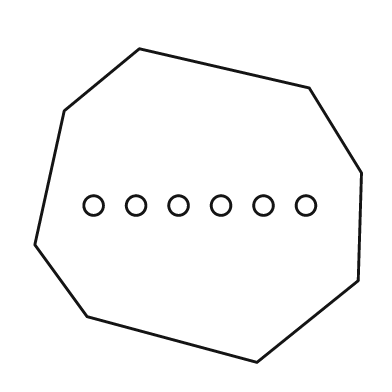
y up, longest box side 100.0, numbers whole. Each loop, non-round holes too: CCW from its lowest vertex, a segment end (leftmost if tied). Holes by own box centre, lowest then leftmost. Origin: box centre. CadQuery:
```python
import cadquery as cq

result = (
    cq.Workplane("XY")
    .moveTo(18.0, -48.0)
    .lineTo(49.0, -23.0)
    .lineTo(50.0, 10.0)
    .lineTo(34.0, 36.0)
    .lineTo(-18.0, 48.0)
    .lineTo(-41.0, 29.0)
    .lineTo(-50.0, -12.0)
    .lineTo(-34.0, -34.0)
    .close()
    .moveTo(-32.0, 0.0)
    .circle(3.0)
    .moveTo(-19.0, 0.0)
    .circle(3.0)
    .moveTo(-6.0, 0.0)
    .circle(3.0)
    .moveTo(7.0, 0.0)
    .circle(3.0)
    .moveTo(20.0, 0.0)
    .circle(3.0)
    .moveTo(33.0, 0.0)
    .circle(3.0)
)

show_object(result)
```